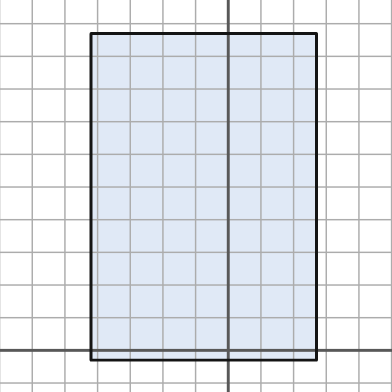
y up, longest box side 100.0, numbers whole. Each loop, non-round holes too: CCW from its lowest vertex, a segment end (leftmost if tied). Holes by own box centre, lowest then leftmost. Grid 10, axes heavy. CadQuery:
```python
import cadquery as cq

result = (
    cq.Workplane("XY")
    .moveTo(-42.0, -3.0)
    .lineTo(27.0, -3.0)
    .lineTo(27.0, 97.0)
    .lineTo(-42.0, 97.0)
    .close()
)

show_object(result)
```